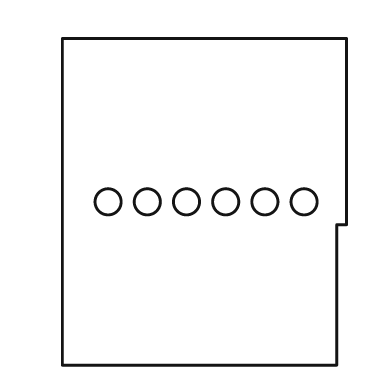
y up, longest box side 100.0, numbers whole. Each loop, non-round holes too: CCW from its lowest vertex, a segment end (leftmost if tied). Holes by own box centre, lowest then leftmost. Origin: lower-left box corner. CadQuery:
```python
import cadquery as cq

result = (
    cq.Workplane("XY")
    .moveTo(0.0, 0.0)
    .lineTo(84.0, 0.0)
    .lineTo(84.0, 43.0)
    .lineTo(87.0, 43.0)
    .lineTo(87.0, 100.0)
    .lineTo(0.0, 100.0)
    .close()
    .moveTo(14.0, 50.0)
    .circle(4.0)
    .moveTo(26.0, 50.0)
    .circle(4.0)
    .moveTo(38.0, 50.0)
    .circle(4.0)
    .moveTo(50.0, 50.0)
    .circle(4.0)
    .moveTo(62.0, 50.0)
    .circle(4.0)
    .moveTo(74.0, 50.0)
    .circle(4.0)
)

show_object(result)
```